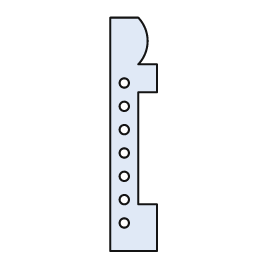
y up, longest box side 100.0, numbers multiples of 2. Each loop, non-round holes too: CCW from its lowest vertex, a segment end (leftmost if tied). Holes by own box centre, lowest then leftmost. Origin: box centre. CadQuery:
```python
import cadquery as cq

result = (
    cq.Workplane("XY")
    .moveTo(-10.0, -50.0)
    .lineTo(10.0, -50.0)
    .lineTo(10.0, -30.0)
    .lineTo(2.0, -30.0)
    .lineTo(2.0, 18.0)
    .lineTo(10.0, 18.0)
    .lineTo(10.0, 30.0)
    .lineTo(2.0, 30.0)
    .threePointArc((6.0, 40.0), (2.0, 50.0))
    .lineTo(-10.0, 50.0)
    .close()
    .moveTo(-4.0, -38.0)
    .circle(2.0)
    .moveTo(-4.0, -28.0)
    .circle(2.0)
    .moveTo(-4.0, -18.0)
    .circle(2.0)
    .moveTo(-4.0, -8.0)
    .circle(2.0)
    .moveTo(-4.0, 2.0)
    .circle(2.0)
    .moveTo(-4.0, 12.0)
    .circle(2.0)
    .moveTo(-4.0, 22.0)
    .circle(2.0)
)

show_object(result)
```